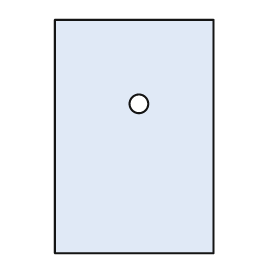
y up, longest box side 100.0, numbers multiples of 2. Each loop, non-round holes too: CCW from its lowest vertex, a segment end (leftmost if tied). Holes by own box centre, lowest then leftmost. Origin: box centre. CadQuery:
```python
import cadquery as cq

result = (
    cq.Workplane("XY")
    .moveTo(-34.0, -50.0)
    .lineTo(34.0, -50.0)
    .lineTo(34.0, 50.0)
    .lineTo(-34.0, 50.0)
    .close()
    .moveTo(2.0, 14.0)
    .circle(4.0)
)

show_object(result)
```